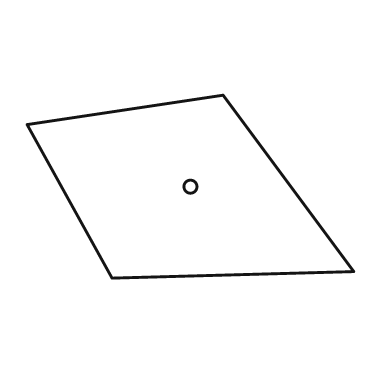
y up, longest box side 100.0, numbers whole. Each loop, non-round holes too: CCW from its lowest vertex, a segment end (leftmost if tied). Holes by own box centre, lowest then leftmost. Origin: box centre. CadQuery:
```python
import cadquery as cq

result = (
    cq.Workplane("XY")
    .moveTo(-24.0, -28.0)
    .lineTo(50.0, -26.0)
    .lineTo(10.0, 28.0)
    .lineTo(-50.0, 19.0)
    .close()
    .moveTo(0.0, 0.0)
    .circle(2.0)
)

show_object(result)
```